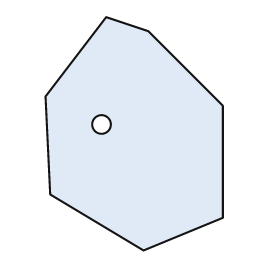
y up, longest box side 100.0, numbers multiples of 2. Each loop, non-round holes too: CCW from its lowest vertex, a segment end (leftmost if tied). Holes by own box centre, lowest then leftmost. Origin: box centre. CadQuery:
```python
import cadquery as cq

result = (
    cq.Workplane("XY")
    .moveTo(4.0, -50.0)
    .lineTo(38.0, -36.0)
    .lineTo(38.0, 12.0)
    .lineTo(6.0, 44.0)
    .lineTo(-12.0, 50.0)
    .lineTo(-38.0, 16.0)
    .lineTo(-36.0, -26.0)
    .close()
    .moveTo(-14.0, 4.0)
    .circle(4.0)
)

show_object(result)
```